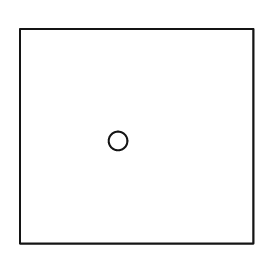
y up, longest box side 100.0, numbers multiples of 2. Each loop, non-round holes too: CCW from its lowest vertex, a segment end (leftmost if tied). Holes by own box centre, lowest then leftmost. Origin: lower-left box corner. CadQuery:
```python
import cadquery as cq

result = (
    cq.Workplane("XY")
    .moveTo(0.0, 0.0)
    .lineTo(100.0, 0.0)
    .lineTo(100.0, 92.0)
    .lineTo(0.0, 92.0)
    .close()
    .moveTo(42.0, 44.0)
    .circle(4.0)
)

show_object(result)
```